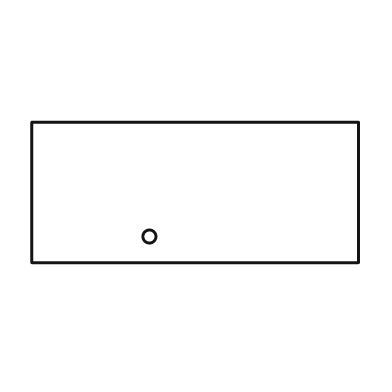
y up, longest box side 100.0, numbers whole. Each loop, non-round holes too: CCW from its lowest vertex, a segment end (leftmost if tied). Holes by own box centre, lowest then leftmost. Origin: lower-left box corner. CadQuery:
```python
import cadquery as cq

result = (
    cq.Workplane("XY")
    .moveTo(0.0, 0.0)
    .lineTo(100.0, 0.0)
    .lineTo(100.0, 43.0)
    .lineTo(0.0, 43.0)
    .close()
    .moveTo(36.0, 8.0)
    .circle(2.0)
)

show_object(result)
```